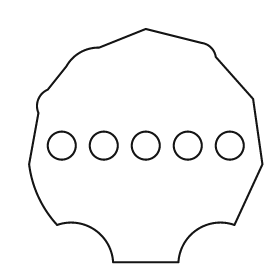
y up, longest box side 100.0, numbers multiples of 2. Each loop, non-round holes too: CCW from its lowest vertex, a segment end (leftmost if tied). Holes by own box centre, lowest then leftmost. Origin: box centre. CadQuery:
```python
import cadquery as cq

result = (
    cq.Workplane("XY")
    .moveTo(-14.0, -50.0)
    .lineTo(14.0, -50.0)
    .threePointArc((22.0, -36.0), (38.0, -34.0))
    .lineTo(50.0, -8.0)
    .lineTo(46.0, 20.0)
    .lineTo(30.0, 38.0)
    .threePointArc((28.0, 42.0), (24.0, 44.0))
    .lineTo(0.0, 50.0)
    .lineTo(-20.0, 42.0)
    .threePointArc((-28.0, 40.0), (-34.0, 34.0))
    .lineTo(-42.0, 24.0)
    .threePointArc((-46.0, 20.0), (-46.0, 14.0))
    .lineTo(-50.0, -8.0)
    .threePointArc((-46.0, -22.0), (-38.0, -34.0))
    .threePointArc((-22.0, -36.0), (-14.0, -50.0))
    .close()
    .moveTo(-36.0, 0.0)
    .circle(6.0)
    .moveTo(-18.0, 0.0)
    .circle(6.0)
    .moveTo(0.0, 0.0)
    .circle(6.0)
    .moveTo(18.0, 0.0)
    .circle(6.0)
    .moveTo(36.0, 0.0)
    .circle(6.0)
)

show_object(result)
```